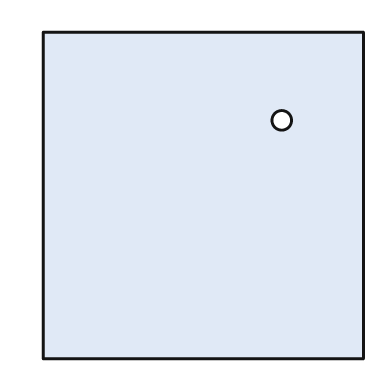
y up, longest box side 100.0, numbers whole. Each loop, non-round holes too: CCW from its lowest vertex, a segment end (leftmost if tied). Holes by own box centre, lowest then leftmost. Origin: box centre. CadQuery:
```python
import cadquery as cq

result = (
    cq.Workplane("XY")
    .moveTo(-49.0, -50.0)
    .lineTo(49.0, -50.0)
    .lineTo(49.0, 50.0)
    .lineTo(-49.0, 50.0)
    .close()
    .moveTo(24.0, 23.0)
    .circle(3.0)
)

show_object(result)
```